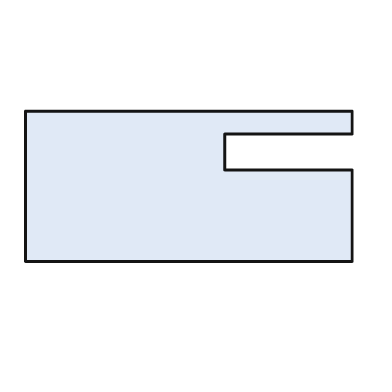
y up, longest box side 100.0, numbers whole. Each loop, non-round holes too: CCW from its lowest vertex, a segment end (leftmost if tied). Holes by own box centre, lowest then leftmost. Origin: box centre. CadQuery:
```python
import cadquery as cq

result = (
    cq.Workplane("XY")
    .moveTo(-50.0, -23.0)
    .lineTo(50.0, -23.0)
    .lineTo(50.0, 5.0)
    .lineTo(11.0, 5.0)
    .lineTo(11.0, 16.0)
    .lineTo(50.0, 16.0)
    .lineTo(50.0, 23.0)
    .lineTo(-50.0, 23.0)
    .close()
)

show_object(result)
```